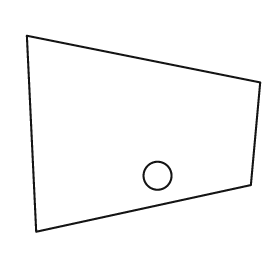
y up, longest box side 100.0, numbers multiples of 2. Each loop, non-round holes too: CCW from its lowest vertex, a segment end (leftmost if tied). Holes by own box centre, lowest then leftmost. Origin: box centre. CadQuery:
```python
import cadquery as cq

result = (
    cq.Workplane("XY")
    .moveTo(-46.0, -42.0)
    .lineTo(46.0, -22.0)
    .lineTo(50.0, 22.0)
    .lineTo(-50.0, 42.0)
    .close()
    .moveTo(6.0, -18.0)
    .circle(6.0)
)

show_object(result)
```